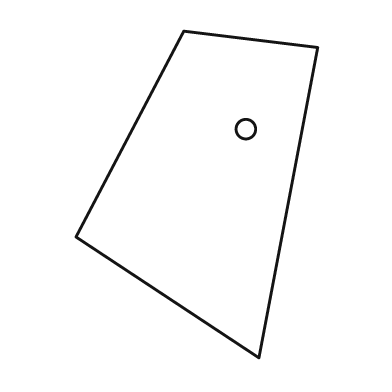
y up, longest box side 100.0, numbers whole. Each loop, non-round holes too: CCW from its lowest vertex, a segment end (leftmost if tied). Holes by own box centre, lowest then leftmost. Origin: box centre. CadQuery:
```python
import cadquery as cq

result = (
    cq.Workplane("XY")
    .moveTo(19.0, -50.0)
    .lineTo(37.0, 45.0)
    .lineTo(-4.0, 50.0)
    .lineTo(-37.0, -13.0)
    .close()
    .moveTo(15.0, 20.0)
    .circle(3.0)
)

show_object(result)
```